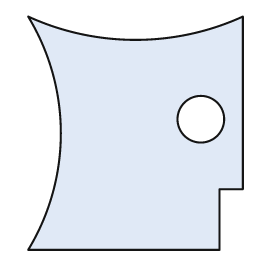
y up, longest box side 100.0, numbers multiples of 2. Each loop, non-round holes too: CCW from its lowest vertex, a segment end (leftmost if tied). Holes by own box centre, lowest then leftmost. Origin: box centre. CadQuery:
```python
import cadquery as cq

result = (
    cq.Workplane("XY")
    .moveTo(-46.0, -50.0)
    .lineTo(36.0, -50.0)
    .lineTo(36.0, -24.0)
    .lineTo(46.0, -24.0)
    .lineTo(46.0, 50.0)
    .threePointArc((0.0, 40.0), (-46.0, 50.0))
    .threePointArc((-32.0, 0.0), (-46.0, -50.0))
    .close()
    .moveTo(28.0, 6.0)
    .circle(10.0)
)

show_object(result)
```